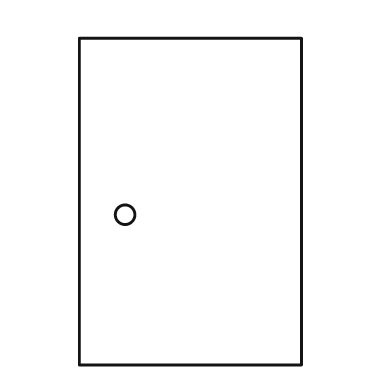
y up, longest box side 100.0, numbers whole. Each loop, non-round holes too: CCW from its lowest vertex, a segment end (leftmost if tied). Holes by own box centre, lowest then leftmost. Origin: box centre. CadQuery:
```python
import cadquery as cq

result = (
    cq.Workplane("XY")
    .moveTo(-34.0, -50.0)
    .lineTo(34.0, -50.0)
    .lineTo(34.0, 50.0)
    .lineTo(-34.0, 50.0)
    .close()
    .moveTo(-20.0, -4.0)
    .circle(3.0)
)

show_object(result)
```